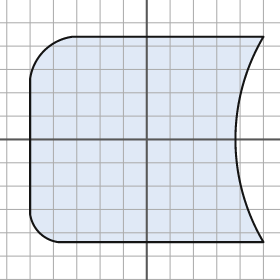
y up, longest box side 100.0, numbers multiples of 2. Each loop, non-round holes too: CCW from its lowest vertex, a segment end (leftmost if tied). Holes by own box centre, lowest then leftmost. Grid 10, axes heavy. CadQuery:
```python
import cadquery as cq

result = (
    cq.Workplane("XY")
    .moveTo(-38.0, -44.0)
    .lineTo(50.0, -44.0)
    .threePointArc((38.0, 0.0), (50.0, 44.0))
    .lineTo(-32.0, 44.0)
    .threePointArc((-44.0, 38.0), (-50.0, 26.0))
    .lineTo(-50.0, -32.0)
    .threePointArc((-46.0, -40.0), (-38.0, -44.0))
    .close()
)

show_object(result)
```